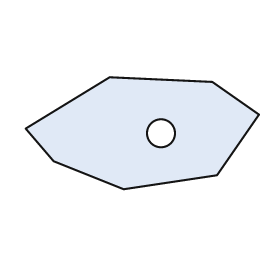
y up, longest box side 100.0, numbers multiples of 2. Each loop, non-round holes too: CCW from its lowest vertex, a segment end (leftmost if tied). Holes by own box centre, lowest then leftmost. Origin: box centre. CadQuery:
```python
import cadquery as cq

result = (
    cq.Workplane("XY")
    .moveTo(-8.0, -24.0)
    .lineTo(32.0, -18.0)
    .lineTo(50.0, 8.0)
    .lineTo(30.0, 22.0)
    .lineTo(-14.0, 24.0)
    .lineTo(-50.0, 2.0)
    .lineTo(-38.0, -12.0)
    .close()
    .moveTo(8.0, 0.0)
    .circle(6.0)
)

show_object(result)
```